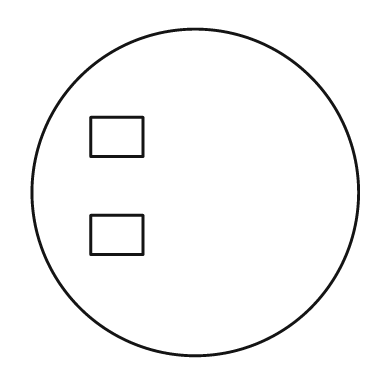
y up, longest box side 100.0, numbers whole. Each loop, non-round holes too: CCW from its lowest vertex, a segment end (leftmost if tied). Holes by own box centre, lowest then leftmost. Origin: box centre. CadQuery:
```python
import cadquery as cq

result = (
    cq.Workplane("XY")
    .moveTo(0.0, 0.0)
    .circle(50.0)
    .moveTo(-32.0, -19.0)
    .lineTo(-16.0, -19.0)
    .lineTo(-16.0, -7.0)
    .lineTo(-32.0, -7.0)
    .close()
    .moveTo(-32.0, 11.0)
    .lineTo(-16.0, 11.0)
    .lineTo(-16.0, 23.0)
    .lineTo(-32.0, 23.0)
    .close()
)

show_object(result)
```